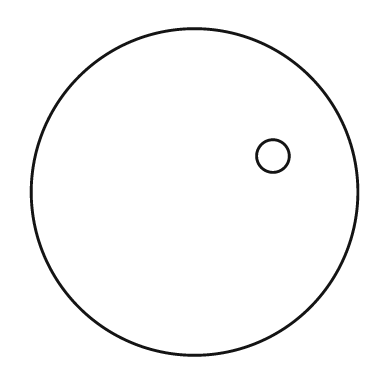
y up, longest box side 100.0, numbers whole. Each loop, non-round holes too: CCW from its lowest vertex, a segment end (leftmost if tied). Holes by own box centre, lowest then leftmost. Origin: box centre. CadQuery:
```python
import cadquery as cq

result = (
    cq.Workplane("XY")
    .moveTo(0.0, 0.0)
    .circle(50.0)
    .moveTo(24.0, 11.0)
    .circle(5.0)
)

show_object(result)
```